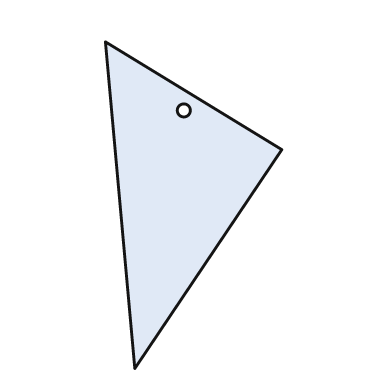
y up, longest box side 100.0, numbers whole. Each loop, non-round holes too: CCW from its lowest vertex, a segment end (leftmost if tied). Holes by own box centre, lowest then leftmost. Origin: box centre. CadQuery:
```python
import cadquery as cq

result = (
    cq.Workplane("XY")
    .moveTo(-18.0, -50.0)
    .lineTo(27.0, 17.0)
    .lineTo(-27.0, 50.0)
    .close()
    .moveTo(-3.0, 29.0)
    .circle(2.0)
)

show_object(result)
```